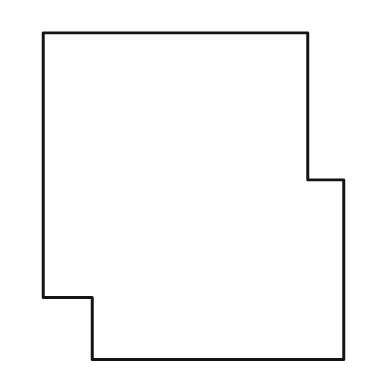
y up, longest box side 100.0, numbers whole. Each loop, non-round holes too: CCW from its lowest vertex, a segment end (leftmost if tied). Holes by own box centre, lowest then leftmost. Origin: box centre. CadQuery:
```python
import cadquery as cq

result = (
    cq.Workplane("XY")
    .moveTo(-31.0, -50.0)
    .lineTo(46.0, -50.0)
    .lineTo(46.0, 5.0)
    .lineTo(35.0, 5.0)
    .lineTo(35.0, 50.0)
    .lineTo(-46.0, 50.0)
    .lineTo(-46.0, -31.0)
    .lineTo(-31.0, -31.0)
    .close()
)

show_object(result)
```